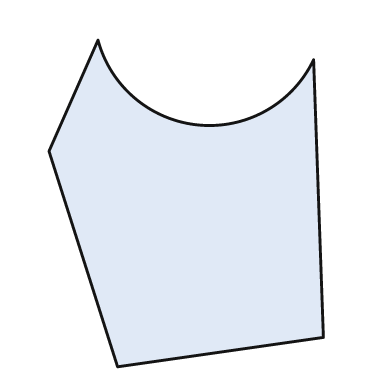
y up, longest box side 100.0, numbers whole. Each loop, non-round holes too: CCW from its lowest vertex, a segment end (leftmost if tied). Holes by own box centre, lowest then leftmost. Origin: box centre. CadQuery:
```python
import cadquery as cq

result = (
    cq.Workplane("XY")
    .moveTo(-21.0, -50.0)
    .lineTo(42.0, -41.0)
    .lineTo(39.0, 44.0)
    .threePointArc((4.0, 24.0), (-27.0, 50.0))
    .lineTo(-42.0, 16.0)
    .close()
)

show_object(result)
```